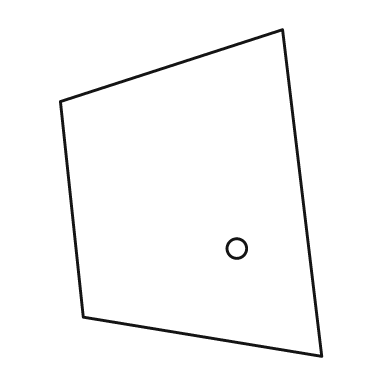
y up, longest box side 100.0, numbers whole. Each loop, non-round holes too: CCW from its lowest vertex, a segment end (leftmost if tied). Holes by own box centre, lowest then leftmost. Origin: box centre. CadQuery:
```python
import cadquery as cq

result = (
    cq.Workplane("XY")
    .moveTo(40.0, -50.0)
    .lineTo(28.0, 50.0)
    .lineTo(-40.0, 28.0)
    .lineTo(-33.0, -38.0)
    .close()
    .moveTo(14.0, -17.0)
    .circle(3.0)
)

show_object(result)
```